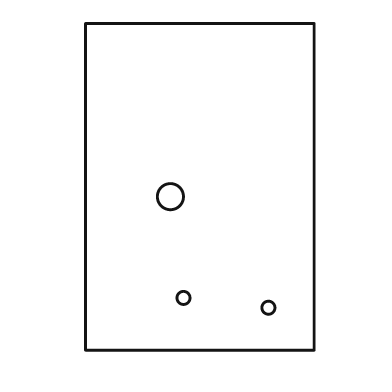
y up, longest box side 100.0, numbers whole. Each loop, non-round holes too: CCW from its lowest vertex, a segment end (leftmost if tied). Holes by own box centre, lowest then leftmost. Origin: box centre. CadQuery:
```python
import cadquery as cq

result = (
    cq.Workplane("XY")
    .moveTo(-35.0, -50.0)
    .lineTo(35.0, -50.0)
    .lineTo(35.0, 50.0)
    .lineTo(-35.0, 50.0)
    .close()
    .moveTo(21.0, -37.0)
    .circle(2.0)
    .moveTo(-5.0, -34.0)
    .circle(2.0)
    .moveTo(-9.0, -3.0)
    .circle(4.0)
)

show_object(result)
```